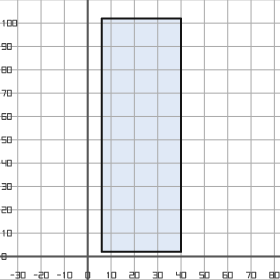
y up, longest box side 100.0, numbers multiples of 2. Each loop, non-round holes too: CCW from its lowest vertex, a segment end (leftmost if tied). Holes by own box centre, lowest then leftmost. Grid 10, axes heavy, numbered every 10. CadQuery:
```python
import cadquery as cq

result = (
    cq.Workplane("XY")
    .moveTo(6.0, 2.0)
    .lineTo(40.0, 2.0)
    .lineTo(40.0, 102.0)
    .lineTo(6.0, 102.0)
    .close()
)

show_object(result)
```